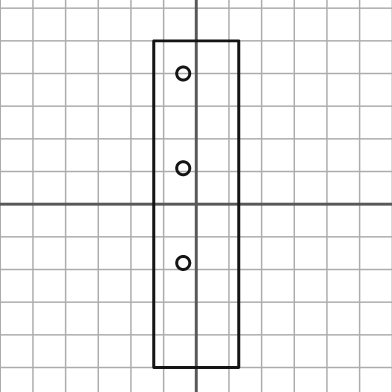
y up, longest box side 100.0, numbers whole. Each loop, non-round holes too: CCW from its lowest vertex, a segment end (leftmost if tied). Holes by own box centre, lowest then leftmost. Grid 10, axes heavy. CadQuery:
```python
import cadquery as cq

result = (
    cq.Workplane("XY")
    .moveTo(-13.0, -50.0)
    .lineTo(13.0, -50.0)
    .lineTo(13.0, 50.0)
    .lineTo(-13.0, 50.0)
    .close()
    .moveTo(-4.0, -18.0)
    .circle(2.0)
    .moveTo(-4.0, 11.0)
    .circle(2.0)
    .moveTo(-4.0, 40.0)
    .circle(2.0)
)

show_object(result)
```